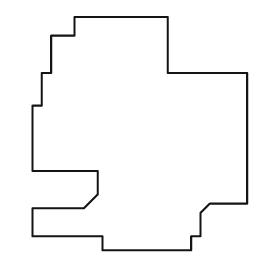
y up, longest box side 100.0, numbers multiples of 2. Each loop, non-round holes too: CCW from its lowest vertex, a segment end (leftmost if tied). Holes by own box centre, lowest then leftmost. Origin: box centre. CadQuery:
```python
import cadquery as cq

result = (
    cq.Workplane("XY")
    .moveTo(-16.0, -50.0)
    .lineTo(22.0, -50.0)
    .lineTo(22.0, -44.0)
    .lineTo(26.0, -44.0)
    .lineTo(26.0, -34.0)
    .lineTo(30.0, -30.0)
    .lineTo(46.0, -30.0)
    .lineTo(46.0, 26.0)
    .lineTo(12.0, 26.0)
    .lineTo(12.0, 50.0)
    .lineTo(-28.0, 50.0)
    .lineTo(-28.0, 42.0)
    .lineTo(-38.0, 42.0)
    .lineTo(-38.0, 26.0)
    .lineTo(-42.0, 26.0)
    .lineTo(-42.0, 12.0)
    .lineTo(-46.0, 12.0)
    .lineTo(-46.0, -16.0)
    .lineTo(-18.0, -16.0)
    .lineTo(-18.0, -26.0)
    .lineTo(-24.0, -32.0)
    .lineTo(-46.0, -32.0)
    .lineTo(-46.0, -44.0)
    .lineTo(-16.0, -44.0)
    .close()
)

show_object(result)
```